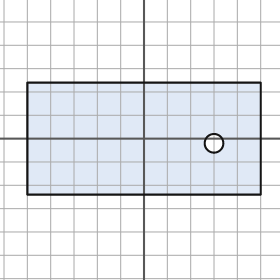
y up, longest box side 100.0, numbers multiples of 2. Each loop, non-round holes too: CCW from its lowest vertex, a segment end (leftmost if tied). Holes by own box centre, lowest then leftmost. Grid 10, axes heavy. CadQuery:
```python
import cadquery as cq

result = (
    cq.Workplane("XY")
    .moveTo(-50.0, -24.0)
    .lineTo(50.0, -24.0)
    .lineTo(50.0, 24.0)
    .lineTo(-50.0, 24.0)
    .close()
    .moveTo(30.0, -2.0)
    .circle(4.0)
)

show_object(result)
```